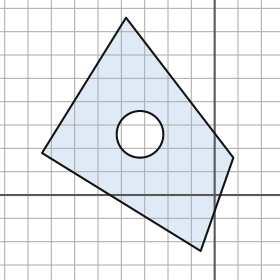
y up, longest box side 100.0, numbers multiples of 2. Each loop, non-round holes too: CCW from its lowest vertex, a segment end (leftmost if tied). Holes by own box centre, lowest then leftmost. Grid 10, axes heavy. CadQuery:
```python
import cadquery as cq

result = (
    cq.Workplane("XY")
    .moveTo(-6.0, -24.0)
    .lineTo(8.0, 16.0)
    .lineTo(-38.0, 76.0)
    .lineTo(-74.0, 18.0)
    .close()
    .moveTo(-32.0, 26.0)
    .circle(10.0)
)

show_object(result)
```